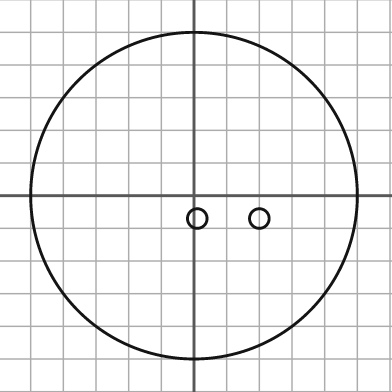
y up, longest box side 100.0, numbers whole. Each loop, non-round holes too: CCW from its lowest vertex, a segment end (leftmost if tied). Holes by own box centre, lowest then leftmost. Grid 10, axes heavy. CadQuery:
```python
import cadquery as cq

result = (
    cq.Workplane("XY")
    .moveTo(0.0, 0.0)
    .circle(50.0)
    .moveTo(1.0, -7.0)
    .circle(3.0)
    .moveTo(20.0, -7.0)
    .circle(3.0)
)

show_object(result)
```